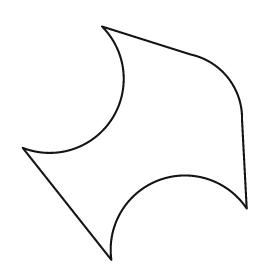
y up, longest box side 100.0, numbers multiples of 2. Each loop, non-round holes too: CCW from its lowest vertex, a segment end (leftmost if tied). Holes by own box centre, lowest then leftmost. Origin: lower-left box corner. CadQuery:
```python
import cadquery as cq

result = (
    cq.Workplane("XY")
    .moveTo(38.0, 0.0)
    .threePointArc((58.0, 34.0), (96.0, 22.0))
    .lineTo(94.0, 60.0)
    .threePointArc((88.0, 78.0), (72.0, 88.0))
    .lineTo(34.0, 100.0)
    .threePointArc((38.0, 60.0), (0.0, 48.0))
    .close()
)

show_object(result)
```